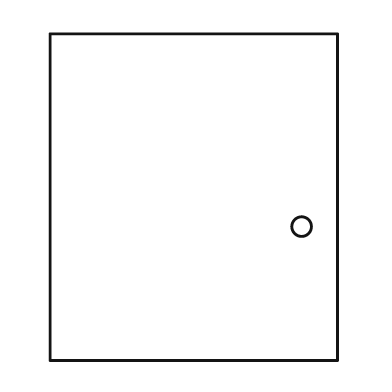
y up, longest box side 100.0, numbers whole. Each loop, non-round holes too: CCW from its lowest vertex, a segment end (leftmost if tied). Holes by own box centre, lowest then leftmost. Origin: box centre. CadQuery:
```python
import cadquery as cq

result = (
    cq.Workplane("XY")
    .moveTo(-44.0, -50.0)
    .lineTo(44.0, -50.0)
    .lineTo(44.0, 50.0)
    .lineTo(-44.0, 50.0)
    .close()
    .moveTo(33.0, -9.0)
    .circle(3.0)
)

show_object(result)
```